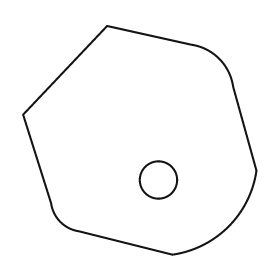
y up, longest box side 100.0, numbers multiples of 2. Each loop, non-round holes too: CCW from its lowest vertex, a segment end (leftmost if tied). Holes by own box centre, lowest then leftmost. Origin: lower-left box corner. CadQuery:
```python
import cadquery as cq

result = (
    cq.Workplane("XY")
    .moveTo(64.0, 0.0)
    .threePointArc((88.0, 12.0), (100.0, 36.0))
    .lineTo(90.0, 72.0)
    .threePointArc((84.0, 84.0), (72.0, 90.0))
    .lineTo(36.0, 98.0)
    .lineTo(0.0, 60.0)
    .lineTo(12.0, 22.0)
    .threePointArc((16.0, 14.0), (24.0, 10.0))
    .close()
    .moveTo(58.0, 32.0)
    .circle(8.0)
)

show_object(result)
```